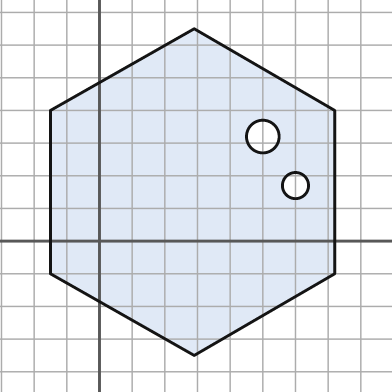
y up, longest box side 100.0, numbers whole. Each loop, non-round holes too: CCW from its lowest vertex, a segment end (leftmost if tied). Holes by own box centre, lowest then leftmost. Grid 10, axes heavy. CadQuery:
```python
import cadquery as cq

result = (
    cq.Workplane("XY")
    .moveTo(29.0, -35.0)
    .lineTo(72.0, -10.0)
    .lineTo(72.0, 40.0)
    .lineTo(29.0, 65.0)
    .lineTo(-15.0, 40.0)
    .lineTo(-15.0, -10.0)
    .close()
    .moveTo(60.0, 17.0)
    .circle(4.0)
    .moveTo(50.0, 32.0)
    .circle(5.0)
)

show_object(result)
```